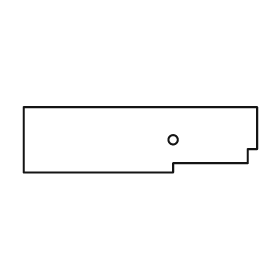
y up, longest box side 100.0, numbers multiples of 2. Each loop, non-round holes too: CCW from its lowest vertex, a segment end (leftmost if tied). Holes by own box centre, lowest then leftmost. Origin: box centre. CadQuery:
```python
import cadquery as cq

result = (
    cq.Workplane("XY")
    .moveTo(-50.0, -14.0)
    .lineTo(14.0, -14.0)
    .lineTo(14.0, -10.0)
    .lineTo(46.0, -10.0)
    .lineTo(46.0, -4.0)
    .lineTo(50.0, -4.0)
    .lineTo(50.0, 14.0)
    .lineTo(-50.0, 14.0)
    .close()
    .moveTo(14.0, 0.0)
    .circle(2.0)
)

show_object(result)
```